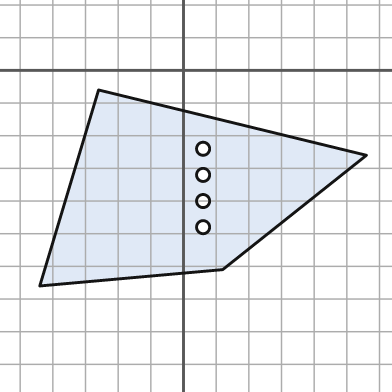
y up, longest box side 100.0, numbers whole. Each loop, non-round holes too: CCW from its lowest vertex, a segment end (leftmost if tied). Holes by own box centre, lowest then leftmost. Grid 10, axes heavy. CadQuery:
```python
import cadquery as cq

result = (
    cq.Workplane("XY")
    .moveTo(-44.0, -66.0)
    .lineTo(12.0, -61.0)
    .lineTo(56.0, -26.0)
    .lineTo(-26.0, -6.0)
    .close()
    .moveTo(6.0, -48.0)
    .circle(2.0)
    .moveTo(6.0, -40.0)
    .circle(2.0)
    .moveTo(6.0, -32.0)
    .circle(2.0)
    .moveTo(6.0, -24.0)
    .circle(2.0)
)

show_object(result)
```